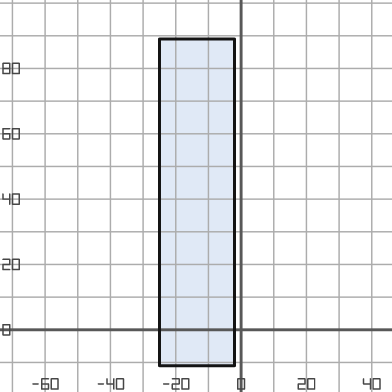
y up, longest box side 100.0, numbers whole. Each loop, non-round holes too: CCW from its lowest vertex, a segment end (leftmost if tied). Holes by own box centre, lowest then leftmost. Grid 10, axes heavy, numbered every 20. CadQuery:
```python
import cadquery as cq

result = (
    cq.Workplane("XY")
    .moveTo(-25.0, -11.0)
    .lineTo(-2.0, -11.0)
    .lineTo(-2.0, 89.0)
    .lineTo(-25.0, 89.0)
    .close()
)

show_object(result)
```